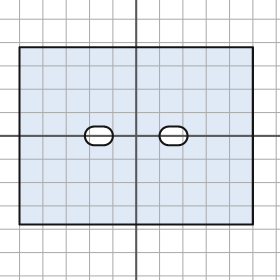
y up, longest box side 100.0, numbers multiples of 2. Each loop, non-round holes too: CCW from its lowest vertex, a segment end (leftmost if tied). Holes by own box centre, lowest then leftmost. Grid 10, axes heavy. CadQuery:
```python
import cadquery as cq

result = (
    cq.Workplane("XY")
    .moveTo(-50.0, -38.0)
    .lineTo(50.0, -38.0)
    .lineTo(50.0, 38.0)
    .lineTo(-50.0, 38.0)
    .close()
    .moveTo(-18.0, -4.0)
    .lineTo(-14.0, -4.0)
    .threePointArc((-10.0, 0.0), (-14.0, 4.0))
    .lineTo(-18.0, 4.0)
    .threePointArc((-22.0, 0.0), (-18.0, -4.0))
    .close()
    .moveTo(14.0, -4.0)
    .lineTo(18.0, -4.0)
    .threePointArc((22.0, 0.0), (18.0, 4.0))
    .lineTo(14.0, 4.0)
    .threePointArc((10.0, 0.0), (14.0, -4.0))
    .close()
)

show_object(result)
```